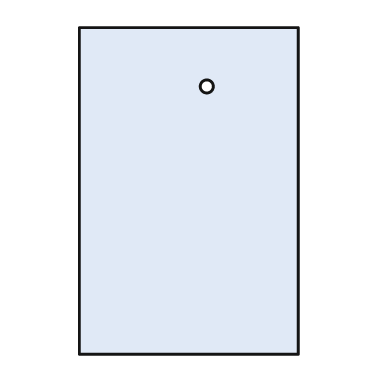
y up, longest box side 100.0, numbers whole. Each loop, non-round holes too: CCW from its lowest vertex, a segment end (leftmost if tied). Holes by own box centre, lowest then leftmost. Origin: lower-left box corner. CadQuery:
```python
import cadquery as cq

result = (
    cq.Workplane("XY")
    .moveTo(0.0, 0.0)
    .lineTo(67.0, 0.0)
    .lineTo(67.0, 100.0)
    .lineTo(0.0, 100.0)
    .close()
    .moveTo(39.0, 82.0)
    .circle(2.0)
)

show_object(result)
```